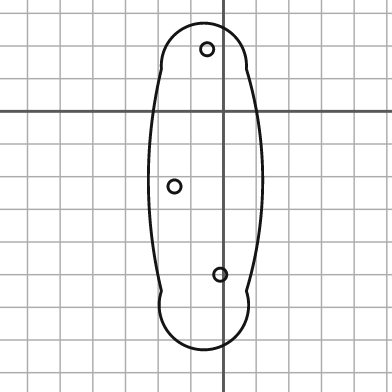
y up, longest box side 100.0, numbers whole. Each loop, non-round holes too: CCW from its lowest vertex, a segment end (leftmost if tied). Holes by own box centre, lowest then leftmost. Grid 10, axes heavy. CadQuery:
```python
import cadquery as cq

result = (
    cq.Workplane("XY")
    .moveTo(-19.0, -55.0)
    .threePointArc((-6.0, -73.0), (7.0, -55.0))
    .threePointArc((12.0, -21.0), (7.0, 13.0))
    .threePointArc((-6.0, 27.0), (-19.0, 13.0))
    .threePointArc((-23.0, -21.0), (-19.0, -55.0))
    .close()
    .moveTo(-1.0, -50.0)
    .circle(2.0)
    .moveTo(-15.0, -23.0)
    .circle(2.0)
    .moveTo(-5.0, 19.0)
    .circle(2.0)
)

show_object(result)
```